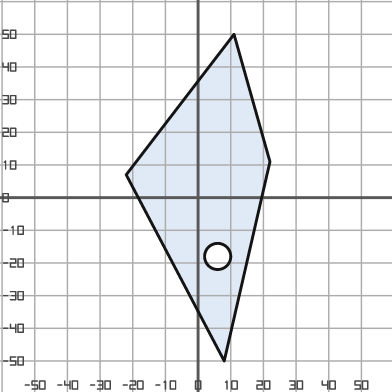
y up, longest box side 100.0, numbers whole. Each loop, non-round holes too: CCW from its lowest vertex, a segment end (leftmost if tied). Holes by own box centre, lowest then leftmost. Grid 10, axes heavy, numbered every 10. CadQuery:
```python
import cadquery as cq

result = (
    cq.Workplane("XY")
    .moveTo(8.0, -50.0)
    .lineTo(22.0, 11.0)
    .lineTo(11.0, 50.0)
    .lineTo(-22.0, 7.0)
    .close()
    .moveTo(6.0, -18.0)
    .circle(4.0)
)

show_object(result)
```